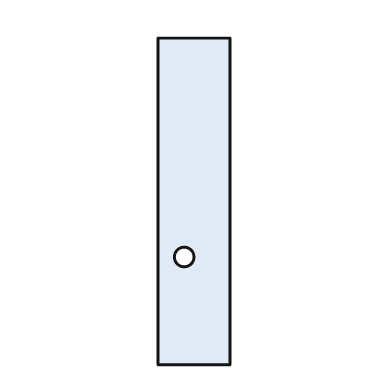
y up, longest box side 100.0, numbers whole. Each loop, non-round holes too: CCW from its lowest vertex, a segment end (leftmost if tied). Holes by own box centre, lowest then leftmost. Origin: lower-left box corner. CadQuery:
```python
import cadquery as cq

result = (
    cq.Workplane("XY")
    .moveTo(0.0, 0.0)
    .lineTo(22.0, 0.0)
    .lineTo(22.0, 100.0)
    .lineTo(0.0, 100.0)
    .close()
    .moveTo(8.0, 33.0)
    .circle(3.0)
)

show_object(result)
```